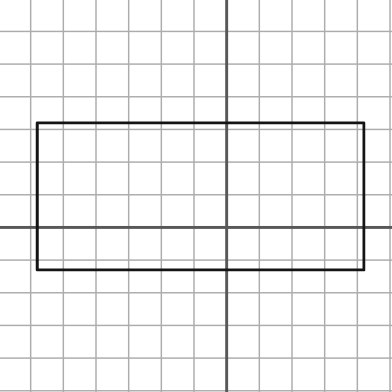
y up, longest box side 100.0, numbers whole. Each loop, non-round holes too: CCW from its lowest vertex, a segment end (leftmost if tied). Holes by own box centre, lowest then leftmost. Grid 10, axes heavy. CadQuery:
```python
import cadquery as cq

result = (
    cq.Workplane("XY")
    .moveTo(-58.0, -13.0)
    .lineTo(42.0, -13.0)
    .lineTo(42.0, 32.0)
    .lineTo(-58.0, 32.0)
    .close()
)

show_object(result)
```